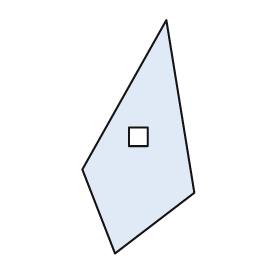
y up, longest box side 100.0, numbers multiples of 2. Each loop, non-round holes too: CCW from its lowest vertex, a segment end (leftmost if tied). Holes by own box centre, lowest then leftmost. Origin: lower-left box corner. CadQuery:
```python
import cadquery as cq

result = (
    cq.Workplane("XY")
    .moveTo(14.0, 0.0)
    .lineTo(48.0, 26.0)
    .lineTo(36.0, 100.0)
    .lineTo(0.0, 36.0)
    .close()
    .moveTo(20.0, 46.0)
    .lineTo(28.0, 46.0)
    .lineTo(28.0, 54.0)
    .lineTo(20.0, 54.0)
    .close()
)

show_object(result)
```